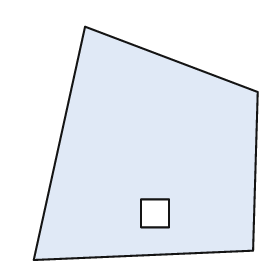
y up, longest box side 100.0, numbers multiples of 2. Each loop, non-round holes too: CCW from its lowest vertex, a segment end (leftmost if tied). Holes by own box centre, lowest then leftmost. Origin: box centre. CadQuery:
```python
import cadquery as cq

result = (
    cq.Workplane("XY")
    .moveTo(-48.0, -50.0)
    .lineTo(46.0, -46.0)
    .lineTo(48.0, 22.0)
    .lineTo(-26.0, 50.0)
    .close()
    .moveTo(-2.0, -36.0)
    .lineTo(10.0, -36.0)
    .lineTo(10.0, -24.0)
    .lineTo(-2.0, -24.0)
    .close()
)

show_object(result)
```